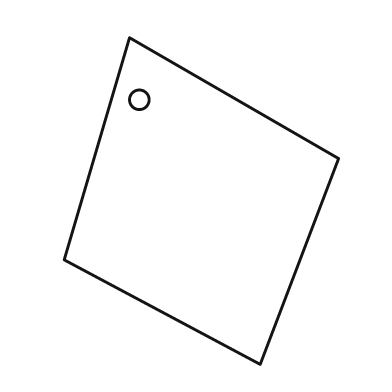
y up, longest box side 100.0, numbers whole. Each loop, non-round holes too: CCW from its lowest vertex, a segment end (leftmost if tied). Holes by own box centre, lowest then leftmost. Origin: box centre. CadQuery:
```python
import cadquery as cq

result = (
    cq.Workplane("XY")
    .moveTo(18.0, -50.0)
    .lineTo(42.0, 13.0)
    .lineTo(-22.0, 50.0)
    .lineTo(-42.0, -18.0)
    .close()
    .moveTo(-19.0, 31.0)
    .circle(3.0)
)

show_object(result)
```